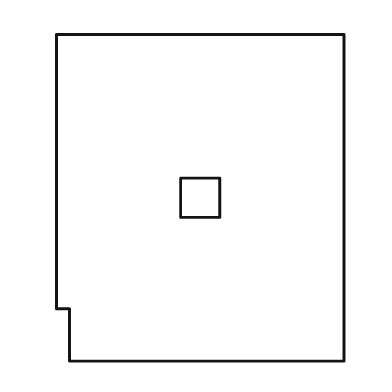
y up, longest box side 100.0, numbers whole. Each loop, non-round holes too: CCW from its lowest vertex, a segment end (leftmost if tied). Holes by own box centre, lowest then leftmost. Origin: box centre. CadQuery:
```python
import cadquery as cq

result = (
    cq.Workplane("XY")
    .moveTo(-40.0, -50.0)
    .lineTo(44.0, -50.0)
    .lineTo(44.0, 50.0)
    .lineTo(-44.0, 50.0)
    .lineTo(-44.0, -34.0)
    .lineTo(-40.0, -34.0)
    .close()
    .moveTo(-6.0, -6.0)
    .lineTo(6.0, -6.0)
    .lineTo(6.0, 6.0)
    .lineTo(-6.0, 6.0)
    .close()
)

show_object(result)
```